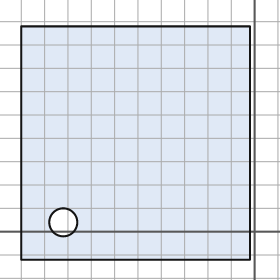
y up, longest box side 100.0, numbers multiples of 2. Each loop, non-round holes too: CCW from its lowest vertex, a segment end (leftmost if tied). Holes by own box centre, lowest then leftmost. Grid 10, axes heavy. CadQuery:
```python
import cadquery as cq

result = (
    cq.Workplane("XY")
    .moveTo(-100.0, -12.0)
    .lineTo(-2.0, -12.0)
    .lineTo(-2.0, 88.0)
    .lineTo(-100.0, 88.0)
    .close()
    .moveTo(-82.0, 4.0)
    .circle(6.0)
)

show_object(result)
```